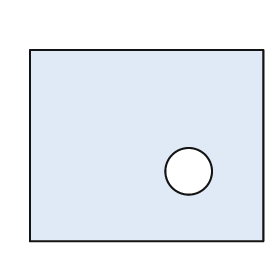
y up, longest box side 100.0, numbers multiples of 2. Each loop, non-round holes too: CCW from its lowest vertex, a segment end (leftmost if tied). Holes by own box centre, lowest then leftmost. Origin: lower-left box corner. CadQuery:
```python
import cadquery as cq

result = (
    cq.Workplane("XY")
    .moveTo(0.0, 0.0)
    .lineTo(100.0, 0.0)
    .lineTo(100.0, 82.0)
    .lineTo(0.0, 82.0)
    .close()
    .moveTo(68.0, 30.0)
    .circle(10.0)
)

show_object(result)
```